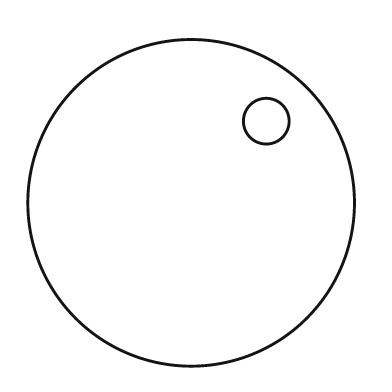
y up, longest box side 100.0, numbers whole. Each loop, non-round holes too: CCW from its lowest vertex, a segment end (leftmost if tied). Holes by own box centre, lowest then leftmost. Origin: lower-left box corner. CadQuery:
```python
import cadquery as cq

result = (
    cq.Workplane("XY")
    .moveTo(50.0, 50.0)
    .circle(50.0)
    .moveTo(73.0, 75.0)
    .circle(7.0)
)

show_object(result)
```